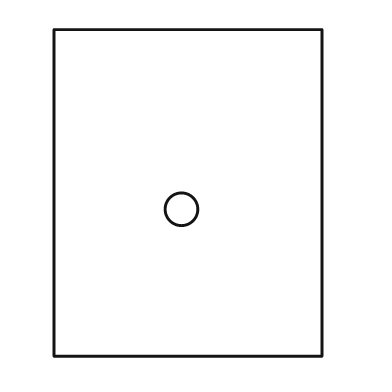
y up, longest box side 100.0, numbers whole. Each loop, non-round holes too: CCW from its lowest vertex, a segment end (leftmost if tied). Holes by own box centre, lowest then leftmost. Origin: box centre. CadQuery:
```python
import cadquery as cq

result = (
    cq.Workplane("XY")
    .moveTo(-41.0, -50.0)
    .lineTo(41.0, -50.0)
    .lineTo(41.0, 50.0)
    .lineTo(-41.0, 50.0)
    .close()
    .moveTo(-2.0, -5.0)
    .circle(5.0)
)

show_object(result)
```